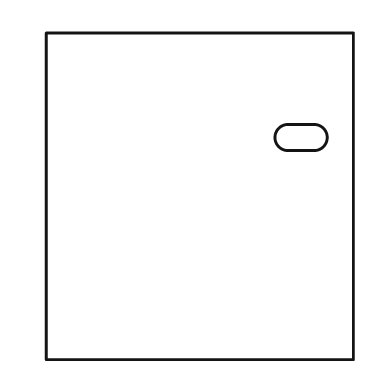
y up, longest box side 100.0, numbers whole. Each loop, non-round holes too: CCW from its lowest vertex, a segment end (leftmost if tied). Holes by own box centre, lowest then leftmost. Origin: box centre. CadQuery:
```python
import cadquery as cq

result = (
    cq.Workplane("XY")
    .moveTo(-47.0, -50.0)
    .lineTo(47.0, -50.0)
    .lineTo(47.0, 50.0)
    .lineTo(-47.0, 50.0)
    .close()
    .moveTo(27.0, 14.0)
    .lineTo(35.0, 14.0)
    .threePointArc((39.0, 18.0), (35.0, 22.0))
    .lineTo(27.0, 22.0)
    .threePointArc((23.0, 18.0), (27.0, 14.0))
    .close()
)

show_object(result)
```